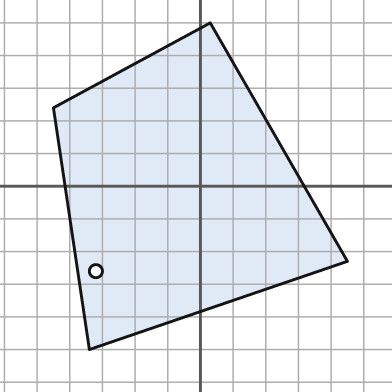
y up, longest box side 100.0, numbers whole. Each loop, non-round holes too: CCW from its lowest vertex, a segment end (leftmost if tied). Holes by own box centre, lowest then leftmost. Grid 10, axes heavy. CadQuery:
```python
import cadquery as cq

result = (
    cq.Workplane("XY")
    .moveTo(-34.0, -50.0)
    .lineTo(45.0, -23.0)
    .lineTo(3.0, 50.0)
    .lineTo(-45.0, 24.0)
    .close()
    .moveTo(-32.0, -26.0)
    .circle(2.0)
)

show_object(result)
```